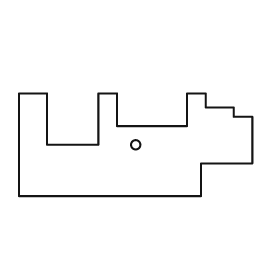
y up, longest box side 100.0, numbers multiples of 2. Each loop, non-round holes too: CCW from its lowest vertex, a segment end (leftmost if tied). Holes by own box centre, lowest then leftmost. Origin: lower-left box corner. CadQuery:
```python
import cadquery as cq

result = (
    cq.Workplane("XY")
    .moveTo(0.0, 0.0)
    .lineTo(78.0, 0.0)
    .lineTo(78.0, 14.0)
    .lineTo(100.0, 14.0)
    .lineTo(100.0, 34.0)
    .lineTo(92.0, 34.0)
    .lineTo(92.0, 38.0)
    .lineTo(80.0, 38.0)
    .lineTo(80.0, 44.0)
    .lineTo(72.0, 44.0)
    .lineTo(72.0, 30.0)
    .lineTo(42.0, 30.0)
    .lineTo(42.0, 44.0)
    .lineTo(34.0, 44.0)
    .lineTo(34.0, 22.0)
    .lineTo(12.0, 22.0)
    .lineTo(12.0, 44.0)
    .lineTo(0.0, 44.0)
    .close()
    .moveTo(50.0, 22.0)
    .circle(2.0)
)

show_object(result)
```